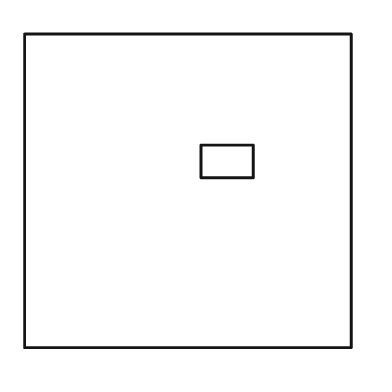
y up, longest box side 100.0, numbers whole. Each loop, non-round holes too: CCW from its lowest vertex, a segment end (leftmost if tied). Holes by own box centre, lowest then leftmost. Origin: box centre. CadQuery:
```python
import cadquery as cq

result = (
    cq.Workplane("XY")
    .moveTo(-50.0, -48.0)
    .lineTo(50.0, -48.0)
    .lineTo(50.0, 48.0)
    .lineTo(-50.0, 48.0)
    .close()
    .moveTo(4.0, 4.0)
    .lineTo(20.0, 4.0)
    .lineTo(20.0, 14.0)
    .lineTo(4.0, 14.0)
    .close()
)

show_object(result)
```